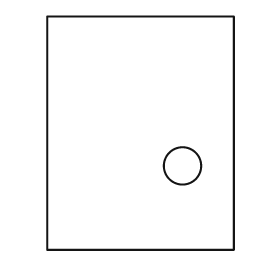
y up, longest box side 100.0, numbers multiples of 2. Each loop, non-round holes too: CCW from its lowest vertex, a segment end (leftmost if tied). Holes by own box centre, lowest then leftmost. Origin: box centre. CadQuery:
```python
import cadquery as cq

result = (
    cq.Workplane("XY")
    .moveTo(-40.0, -50.0)
    .lineTo(40.0, -50.0)
    .lineTo(40.0, 50.0)
    .lineTo(-40.0, 50.0)
    .close()
    .moveTo(18.0, -14.0)
    .circle(8.0)
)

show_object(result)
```